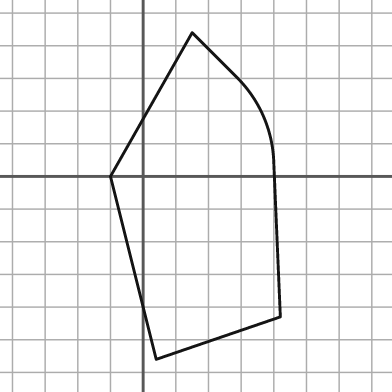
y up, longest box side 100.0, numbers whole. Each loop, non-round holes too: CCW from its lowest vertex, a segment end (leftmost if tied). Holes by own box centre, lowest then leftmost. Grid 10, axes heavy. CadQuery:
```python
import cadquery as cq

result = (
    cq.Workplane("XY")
    .moveTo(4.0, -56.0)
    .lineTo(42.0, -43.0)
    .lineTo(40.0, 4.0)
    .threePointArc((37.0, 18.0), (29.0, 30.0))
    .lineTo(15.0, 44.0)
    .lineTo(-10.0, 0.0)
    .close()
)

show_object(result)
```